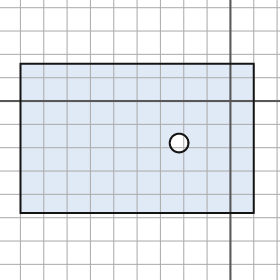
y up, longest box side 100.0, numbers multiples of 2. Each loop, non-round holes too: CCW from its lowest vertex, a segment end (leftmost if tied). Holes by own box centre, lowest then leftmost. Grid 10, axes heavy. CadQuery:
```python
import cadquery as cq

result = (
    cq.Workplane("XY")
    .moveTo(-90.0, -48.0)
    .lineTo(10.0, -48.0)
    .lineTo(10.0, 16.0)
    .lineTo(-90.0, 16.0)
    .close()
    .moveTo(-22.0, -18.0)
    .circle(4.0)
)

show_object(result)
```